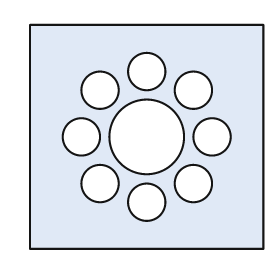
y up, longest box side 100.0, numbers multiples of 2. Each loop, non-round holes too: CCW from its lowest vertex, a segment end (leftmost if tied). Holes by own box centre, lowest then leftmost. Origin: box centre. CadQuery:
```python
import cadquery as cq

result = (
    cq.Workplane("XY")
    .moveTo(-50.0, -48.0)
    .lineTo(50.0, -48.0)
    .lineTo(50.0, 48.0)
    .lineTo(-50.0, 48.0)
    .close()
    .moveTo(0.0, -28.0)
    .circle(8.0)
    .moveTo(-20.0, -20.0)
    .circle(8.0)
    .moveTo(20.0, -20.0)
    .circle(8.0)
    .moveTo(-28.0, 0.0)
    .circle(8.0)
    .moveTo(0.0, 0.0)
    .circle(16.0)
    .moveTo(28.0, 0.0)
    .circle(8.0)
    .moveTo(-20.0, 20.0)
    .circle(8.0)
    .moveTo(20.0, 20.0)
    .circle(8.0)
    .moveTo(0.0, 28.0)
    .circle(8.0)
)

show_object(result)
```